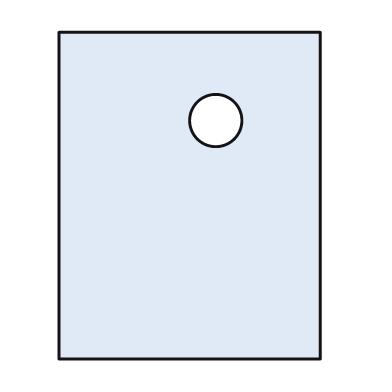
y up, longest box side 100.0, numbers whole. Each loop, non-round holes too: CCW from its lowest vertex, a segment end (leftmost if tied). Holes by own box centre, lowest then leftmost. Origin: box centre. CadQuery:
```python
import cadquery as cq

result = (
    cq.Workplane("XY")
    .moveTo(-40.0, -50.0)
    .lineTo(40.0, -50.0)
    .lineTo(40.0, 50.0)
    .lineTo(-40.0, 50.0)
    .close()
    .moveTo(8.0, 23.0)
    .circle(8.0)
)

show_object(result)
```